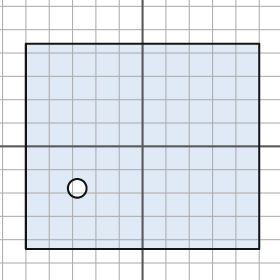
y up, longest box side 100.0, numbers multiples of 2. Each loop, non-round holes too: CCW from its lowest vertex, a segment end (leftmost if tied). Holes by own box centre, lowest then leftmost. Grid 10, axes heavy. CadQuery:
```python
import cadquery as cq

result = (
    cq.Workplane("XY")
    .moveTo(-50.0, -44.0)
    .lineTo(50.0, -44.0)
    .lineTo(50.0, 44.0)
    .lineTo(-50.0, 44.0)
    .close()
    .moveTo(-28.0, -18.0)
    .circle(4.0)
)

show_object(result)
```